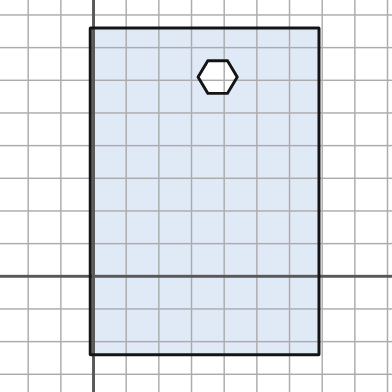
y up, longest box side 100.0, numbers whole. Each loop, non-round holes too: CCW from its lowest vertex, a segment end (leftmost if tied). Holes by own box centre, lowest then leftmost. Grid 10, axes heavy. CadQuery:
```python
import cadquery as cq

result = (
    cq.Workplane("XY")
    .moveTo(-1.0, -24.0)
    .lineTo(69.0, -24.0)
    .lineTo(69.0, 76.0)
    .lineTo(-1.0, 76.0)
    .close()
    .moveTo(35.0, 56.0)
    .lineTo(41.0, 56.0)
    .lineTo(44.0, 61.0)
    .lineTo(41.0, 66.0)
    .lineTo(35.0, 66.0)
    .lineTo(32.0, 61.0)
    .close()
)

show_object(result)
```